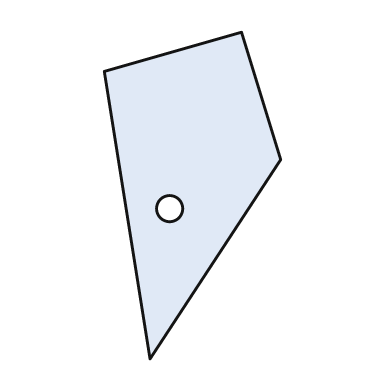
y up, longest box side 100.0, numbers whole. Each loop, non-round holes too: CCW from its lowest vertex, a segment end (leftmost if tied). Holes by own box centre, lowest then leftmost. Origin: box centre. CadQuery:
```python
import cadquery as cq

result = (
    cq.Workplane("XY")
    .moveTo(-13.0, -50.0)
    .lineTo(27.0, 11.0)
    .lineTo(15.0, 50.0)
    .lineTo(-27.0, 38.0)
    .close()
    .moveTo(-7.0, -4.0)
    .circle(4.0)
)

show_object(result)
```